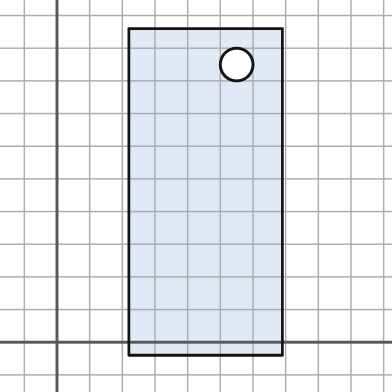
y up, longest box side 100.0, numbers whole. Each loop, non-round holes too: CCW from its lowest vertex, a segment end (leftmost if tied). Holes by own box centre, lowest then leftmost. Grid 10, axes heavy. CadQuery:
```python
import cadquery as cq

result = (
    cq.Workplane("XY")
    .moveTo(22.0, -4.0)
    .lineTo(69.0, -4.0)
    .lineTo(69.0, 96.0)
    .lineTo(22.0, 96.0)
    .close()
    .moveTo(55.0, 85.0)
    .circle(5.0)
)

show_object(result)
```